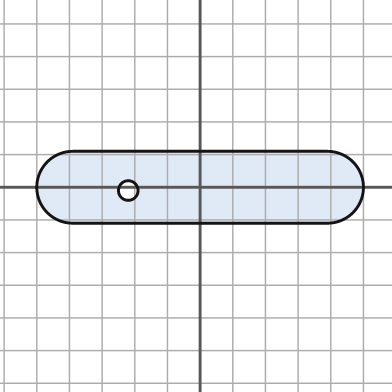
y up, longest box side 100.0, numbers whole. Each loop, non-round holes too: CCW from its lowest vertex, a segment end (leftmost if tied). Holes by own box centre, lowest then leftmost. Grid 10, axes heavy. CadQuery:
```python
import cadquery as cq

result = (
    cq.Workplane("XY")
    .moveTo(-39.0, -11.0)
    .lineTo(39.0, -11.0)
    .threePointArc((50.0, 0.0), (39.0, 11.0))
    .lineTo(-39.0, 11.0)
    .threePointArc((-50.0, 0.0), (-39.0, -11.0))
    .close()
    .moveTo(-22.0, -1.0)
    .circle(3.0)
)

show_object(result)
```